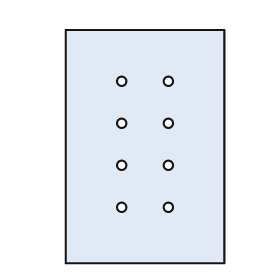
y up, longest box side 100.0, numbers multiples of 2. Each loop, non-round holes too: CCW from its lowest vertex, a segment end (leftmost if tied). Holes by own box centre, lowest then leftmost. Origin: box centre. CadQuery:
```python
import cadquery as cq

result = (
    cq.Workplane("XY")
    .moveTo(-34.0, -50.0)
    .lineTo(34.0, -50.0)
    .lineTo(34.0, 50.0)
    .lineTo(-34.0, 50.0)
    .close()
    .moveTo(-10.0, -26.0)
    .circle(2.0)
    .moveTo(10.0, -26.0)
    .circle(2.0)
    .moveTo(-10.0, -8.0)
    .circle(2.0)
    .moveTo(10.0, -8.0)
    .circle(2.0)
    .moveTo(-10.0, 10.0)
    .circle(2.0)
    .moveTo(10.0, 10.0)
    .circle(2.0)
    .moveTo(-10.0, 28.0)
    .circle(2.0)
    .moveTo(10.0, 28.0)
    .circle(2.0)
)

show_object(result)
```